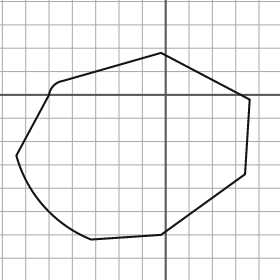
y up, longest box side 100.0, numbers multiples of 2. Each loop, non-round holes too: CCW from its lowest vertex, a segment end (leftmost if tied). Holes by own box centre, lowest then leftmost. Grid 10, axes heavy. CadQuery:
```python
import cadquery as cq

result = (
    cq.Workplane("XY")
    .moveTo(-32.0, -62.0)
    .lineTo(-2.0, -60.0)
    .lineTo(34.0, -34.0)
    .lineTo(36.0, -2.0)
    .lineTo(-2.0, 18.0)
    .lineTo(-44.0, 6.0)
    .threePointArc((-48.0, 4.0), (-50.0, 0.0))
    .lineTo(-64.0, -26.0)
    .threePointArc((-52.0, -48.0), (-32.0, -62.0))
    .close()
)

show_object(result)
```